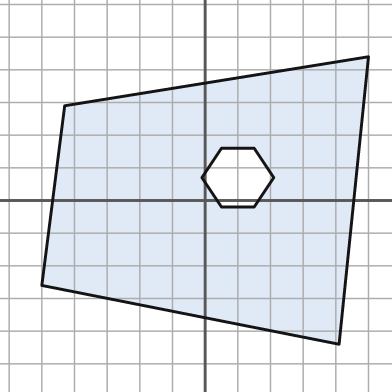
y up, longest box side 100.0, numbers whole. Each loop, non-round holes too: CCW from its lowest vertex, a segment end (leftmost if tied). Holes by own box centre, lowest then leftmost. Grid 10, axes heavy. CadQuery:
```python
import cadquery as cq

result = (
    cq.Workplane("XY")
    .moveTo(41.0, -44.0)
    .lineTo(50.0, 44.0)
    .lineTo(-43.0, 29.0)
    .lineTo(-50.0, -26.0)
    .close()
    .moveTo(5.0, -2.0)
    .lineTo(15.0, -2.0)
    .lineTo(21.0, 7.0)
    .lineTo(15.0, 16.0)
    .lineTo(5.0, 16.0)
    .lineTo(-1.0, 7.0)
    .close()
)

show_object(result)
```